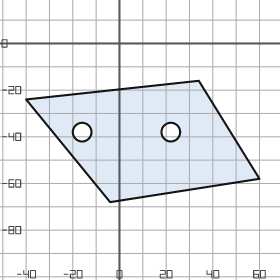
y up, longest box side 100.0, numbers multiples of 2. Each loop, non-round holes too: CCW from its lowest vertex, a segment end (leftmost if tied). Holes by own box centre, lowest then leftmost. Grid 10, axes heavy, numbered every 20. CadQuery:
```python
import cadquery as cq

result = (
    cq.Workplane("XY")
    .moveTo(-4.0, -68.0)
    .lineTo(60.0, -58.0)
    .lineTo(34.0, -16.0)
    .lineTo(-40.0, -24.0)
    .close()
    .moveTo(-16.0, -38.0)
    .circle(4.0)
    .moveTo(22.0, -38.0)
    .circle(4.0)
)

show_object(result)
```